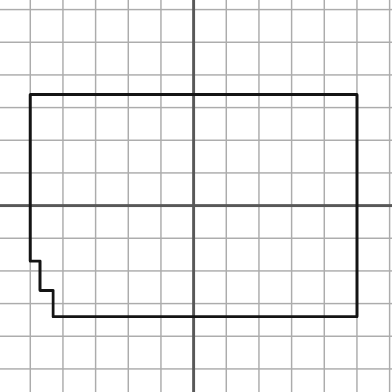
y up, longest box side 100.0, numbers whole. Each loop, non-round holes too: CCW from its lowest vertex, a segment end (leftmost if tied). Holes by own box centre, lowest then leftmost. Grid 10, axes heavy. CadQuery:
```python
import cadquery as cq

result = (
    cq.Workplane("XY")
    .moveTo(-43.0, -34.0)
    .lineTo(50.0, -34.0)
    .lineTo(50.0, 34.0)
    .lineTo(-50.0, 34.0)
    .lineTo(-50.0, -17.0)
    .lineTo(-47.0, -17.0)
    .lineTo(-47.0, -26.0)
    .lineTo(-43.0, -26.0)
    .close()
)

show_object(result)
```